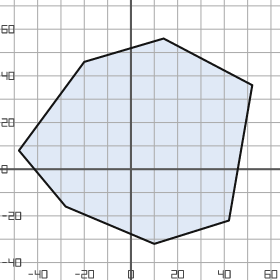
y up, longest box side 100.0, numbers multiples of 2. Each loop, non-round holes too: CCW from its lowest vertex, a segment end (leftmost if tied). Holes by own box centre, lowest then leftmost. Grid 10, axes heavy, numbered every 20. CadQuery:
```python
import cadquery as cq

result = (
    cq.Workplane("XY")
    .moveTo(10.0, -32.0)
    .lineTo(42.0, -22.0)
    .lineTo(52.0, 36.0)
    .lineTo(14.0, 56.0)
    .lineTo(-20.0, 46.0)
    .lineTo(-48.0, 8.0)
    .lineTo(-28.0, -16.0)
    .close()
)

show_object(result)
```